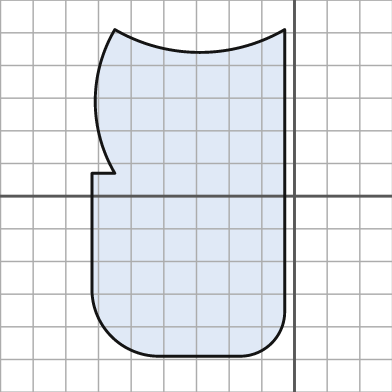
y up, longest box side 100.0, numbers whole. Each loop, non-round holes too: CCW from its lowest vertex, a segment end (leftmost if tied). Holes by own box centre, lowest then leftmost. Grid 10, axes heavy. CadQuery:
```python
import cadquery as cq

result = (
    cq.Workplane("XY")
    .moveTo(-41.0, -49.0)
    .lineTo(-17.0, -49.0)
    .threePointArc((-7.0, -45.0), (-3.0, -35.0))
    .lineTo(-3.0, 51.0)
    .threePointArc((-29.0, 44.0), (-55.0, 51.0))
    .threePointArc((-61.0, 29.0), (-55.0, 7.0))
    .lineTo(-62.0, 7.0)
    .lineTo(-62.0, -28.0)
    .threePointArc((-56.0, -43.0), (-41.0, -49.0))
    .close()
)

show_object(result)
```